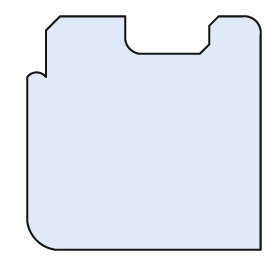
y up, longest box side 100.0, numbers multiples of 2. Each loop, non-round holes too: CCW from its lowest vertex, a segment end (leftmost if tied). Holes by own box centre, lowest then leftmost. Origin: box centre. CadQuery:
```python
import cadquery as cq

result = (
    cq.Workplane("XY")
    .moveTo(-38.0, -50.0)
    .lineTo(50.0, -50.0)
    .lineTo(50.0, 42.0)
    .threePointArc((48.0, 48.0), (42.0, 50.0))
    .lineTo(32.0, 50.0)
    .lineTo(28.0, 46.0)
    .lineTo(28.0, 38.0)
    .lineTo(24.0, 34.0)
    .lineTo(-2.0, 34.0)
    .threePointArc((-6.0, 36.0), (-8.0, 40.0))
    .lineTo(-8.0, 50.0)
    .lineTo(-36.0, 50.0)
    .lineTo(-42.0, 44.0)
    .lineTo(-42.0, 24.0)
    .threePointArc((-46.0, 26.0), (-50.0, 24.0))
    .lineTo(-50.0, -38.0)
    .threePointArc((-46.0, -46.0), (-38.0, -50.0))
    .close()
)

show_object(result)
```